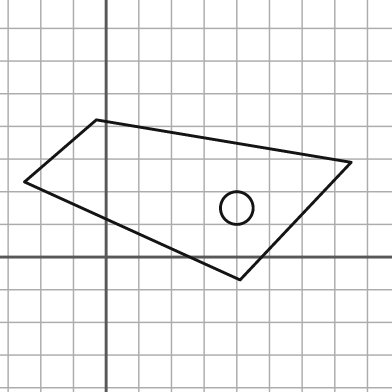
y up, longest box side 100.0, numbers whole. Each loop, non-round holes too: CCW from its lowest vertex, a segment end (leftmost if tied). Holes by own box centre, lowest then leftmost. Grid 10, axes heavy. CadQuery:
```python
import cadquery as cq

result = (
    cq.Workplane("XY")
    .moveTo(41.0, -7.0)
    .lineTo(75.0, 29.0)
    .lineTo(-3.0, 42.0)
    .lineTo(-25.0, 23.0)
    .close()
    .moveTo(40.0, 15.0)
    .circle(5.0)
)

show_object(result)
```